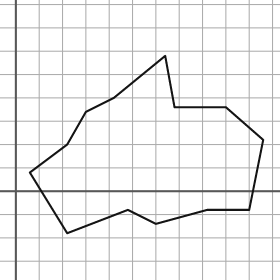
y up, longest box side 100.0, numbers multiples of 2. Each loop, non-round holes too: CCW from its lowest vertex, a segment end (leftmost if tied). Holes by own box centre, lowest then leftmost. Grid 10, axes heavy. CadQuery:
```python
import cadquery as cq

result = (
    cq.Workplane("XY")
    .moveTo(22.0, -18.0)
    .lineTo(48.0, -8.0)
    .lineTo(60.0, -14.0)
    .lineTo(82.0, -8.0)
    .lineTo(100.0, -8.0)
    .lineTo(106.0, 22.0)
    .lineTo(90.0, 36.0)
    .lineTo(68.0, 36.0)
    .lineTo(64.0, 58.0)
    .lineTo(42.0, 40.0)
    .lineTo(30.0, 34.0)
    .lineTo(22.0, 20.0)
    .lineTo(6.0, 8.0)
    .close()
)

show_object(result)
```